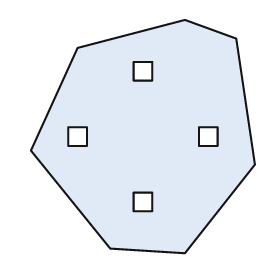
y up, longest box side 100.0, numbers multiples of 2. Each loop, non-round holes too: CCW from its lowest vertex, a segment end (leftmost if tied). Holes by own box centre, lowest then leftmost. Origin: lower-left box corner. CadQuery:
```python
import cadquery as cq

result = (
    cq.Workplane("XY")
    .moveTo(66.0, 0.0)
    .lineTo(96.0, 38.0)
    .lineTo(88.0, 92.0)
    .lineTo(66.0, 100.0)
    .lineTo(20.0, 88.0)
    .lineTo(0.0, 44.0)
    .lineTo(34.0, 2.0)
    .close()
    .moveTo(44.0, 18.0)
    .lineTo(52.0, 18.0)
    .lineTo(52.0, 26.0)
    .lineTo(44.0, 26.0)
    .close()
    .moveTo(16.0, 46.0)
    .lineTo(24.0, 46.0)
    .lineTo(24.0, 54.0)
    .lineTo(16.0, 54.0)
    .close()
    .moveTo(72.0, 46.0)
    .lineTo(80.0, 46.0)
    .lineTo(80.0, 54.0)
    .lineTo(72.0, 54.0)
    .close()
    .moveTo(44.0, 74.0)
    .lineTo(52.0, 74.0)
    .lineTo(52.0, 82.0)
    .lineTo(44.0, 82.0)
    .close()
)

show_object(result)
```